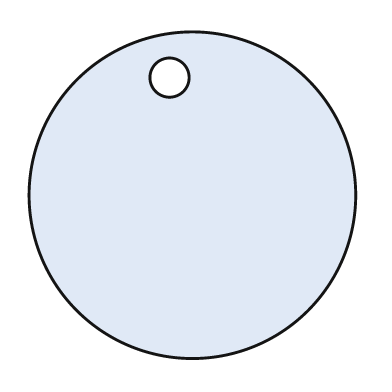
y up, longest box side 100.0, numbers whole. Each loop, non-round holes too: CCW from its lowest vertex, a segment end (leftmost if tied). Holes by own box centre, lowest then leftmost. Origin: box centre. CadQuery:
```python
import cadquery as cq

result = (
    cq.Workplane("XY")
    .moveTo(0.0, 0.0)
    .circle(50.0)
    .moveTo(-7.0, 36.0)
    .circle(6.0)
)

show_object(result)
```